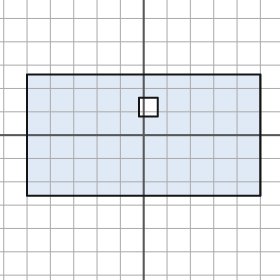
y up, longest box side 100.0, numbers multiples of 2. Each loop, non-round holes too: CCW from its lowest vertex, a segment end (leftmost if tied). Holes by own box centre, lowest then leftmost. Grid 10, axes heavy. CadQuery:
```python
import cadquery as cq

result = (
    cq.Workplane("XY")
    .moveTo(-50.0, -26.0)
    .lineTo(50.0, -26.0)
    .lineTo(50.0, 26.0)
    .lineTo(-50.0, 26.0)
    .close()
    .moveTo(-2.0, 8.0)
    .lineTo(6.0, 8.0)
    .lineTo(6.0, 16.0)
    .lineTo(-2.0, 16.0)
    .close()
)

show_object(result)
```